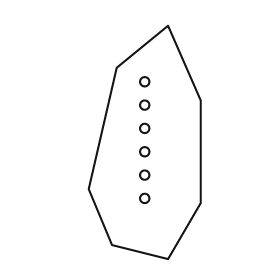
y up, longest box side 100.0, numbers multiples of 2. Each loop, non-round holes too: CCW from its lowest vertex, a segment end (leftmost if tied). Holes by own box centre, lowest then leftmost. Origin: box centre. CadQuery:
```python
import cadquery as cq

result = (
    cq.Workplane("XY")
    .moveTo(10.0, -50.0)
    .lineTo(24.0, -26.0)
    .lineTo(24.0, 18.0)
    .lineTo(10.0, 50.0)
    .lineTo(-12.0, 32.0)
    .lineTo(-24.0, -20.0)
    .lineTo(-14.0, -44.0)
    .close()
    .moveTo(0.0, -24.0)
    .circle(2.0)
    .moveTo(0.0, -14.0)
    .circle(2.0)
    .moveTo(0.0, -4.0)
    .circle(2.0)
    .moveTo(0.0, 6.0)
    .circle(2.0)
    .moveTo(0.0, 16.0)
    .circle(2.0)
    .moveTo(0.0, 26.0)
    .circle(2.0)
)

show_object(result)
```